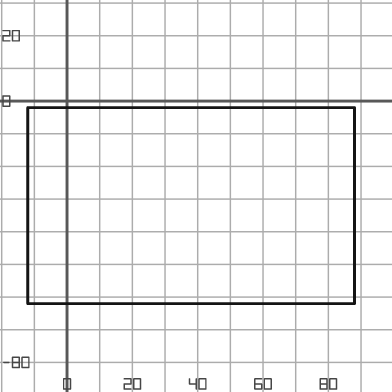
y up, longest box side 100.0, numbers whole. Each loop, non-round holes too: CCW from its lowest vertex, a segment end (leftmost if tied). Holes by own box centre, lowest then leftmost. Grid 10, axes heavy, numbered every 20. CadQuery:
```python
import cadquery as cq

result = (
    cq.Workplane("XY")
    .moveTo(-12.0, -62.0)
    .lineTo(88.0, -62.0)
    .lineTo(88.0, -2.0)
    .lineTo(-12.0, -2.0)
    .close()
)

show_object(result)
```